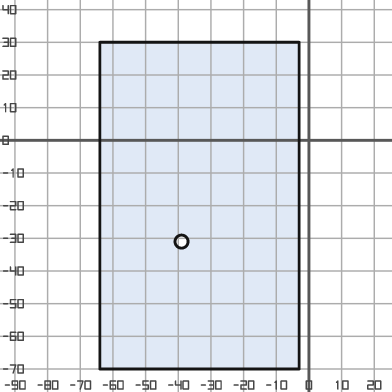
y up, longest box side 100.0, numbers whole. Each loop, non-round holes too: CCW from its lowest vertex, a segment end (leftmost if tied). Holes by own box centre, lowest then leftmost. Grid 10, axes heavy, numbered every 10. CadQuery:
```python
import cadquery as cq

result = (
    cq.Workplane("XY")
    .moveTo(-64.0, -70.0)
    .lineTo(-3.0, -70.0)
    .lineTo(-3.0, 30.0)
    .lineTo(-64.0, 30.0)
    .close()
    .moveTo(-39.0, -31.0)
    .circle(2.0)
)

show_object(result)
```